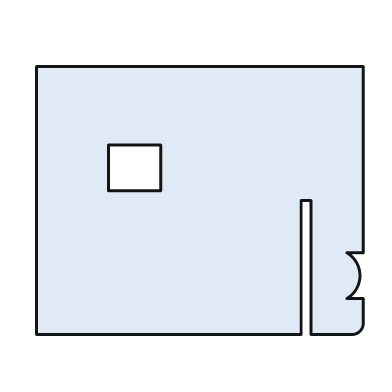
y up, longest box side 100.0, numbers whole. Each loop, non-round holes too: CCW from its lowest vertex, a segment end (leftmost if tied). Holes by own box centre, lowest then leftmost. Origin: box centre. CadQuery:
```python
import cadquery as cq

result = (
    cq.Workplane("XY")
    .moveTo(-50.0, -41.0)
    .lineTo(31.0, -41.0)
    .lineTo(31.0, 0.0)
    .lineTo(34.0, 0.0)
    .lineTo(34.0, -41.0)
    .lineTo(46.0, -41.0)
    .threePointArc((49.0, -40.0), (50.0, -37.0))
    .lineTo(50.0, -30.0)
    .lineTo(45.0, -30.0)
    .threePointArc((49.0, -23.0), (45.0, -16.0))
    .lineTo(50.0, -16.0)
    .lineTo(50.0, 41.0)
    .lineTo(-50.0, 41.0)
    .close()
    .moveTo(-28.0, 3.0)
    .lineTo(-12.0, 3.0)
    .lineTo(-12.0, 17.0)
    .lineTo(-28.0, 17.0)
    .close()
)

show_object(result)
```